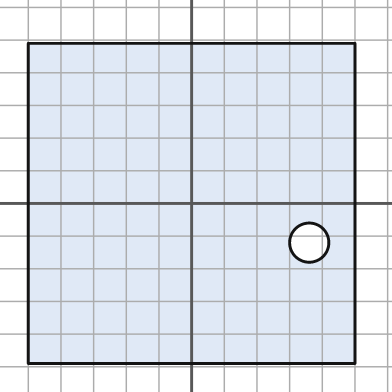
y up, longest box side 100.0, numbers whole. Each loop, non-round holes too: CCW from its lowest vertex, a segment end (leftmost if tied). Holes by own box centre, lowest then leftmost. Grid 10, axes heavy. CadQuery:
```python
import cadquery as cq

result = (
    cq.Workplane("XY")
    .moveTo(-50.0, -49.0)
    .lineTo(50.0, -49.0)
    .lineTo(50.0, 49.0)
    .lineTo(-50.0, 49.0)
    .close()
    .moveTo(36.0, -12.0)
    .circle(6.0)
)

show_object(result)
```